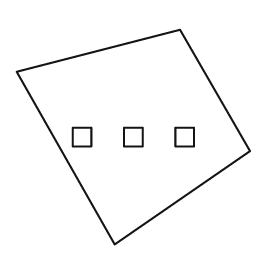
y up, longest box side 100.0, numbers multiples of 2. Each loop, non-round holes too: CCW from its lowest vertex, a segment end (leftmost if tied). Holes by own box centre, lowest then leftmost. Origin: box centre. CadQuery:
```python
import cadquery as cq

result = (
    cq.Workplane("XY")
    .moveTo(-8.0, -46.0)
    .lineTo(50.0, -6.0)
    .lineTo(20.0, 46.0)
    .lineTo(-50.0, 28.0)
    .close()
    .moveTo(-26.0, -4.0)
    .lineTo(-18.0, -4.0)
    .lineTo(-18.0, 4.0)
    .lineTo(-26.0, 4.0)
    .close()
    .moveTo(-4.0, -4.0)
    .lineTo(4.0, -4.0)
    .lineTo(4.0, 4.0)
    .lineTo(-4.0, 4.0)
    .close()
    .moveTo(18.0, -4.0)
    .lineTo(26.0, -4.0)
    .lineTo(26.0, 4.0)
    .lineTo(18.0, 4.0)
    .close()
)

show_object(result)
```